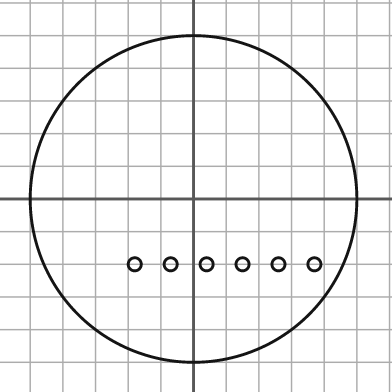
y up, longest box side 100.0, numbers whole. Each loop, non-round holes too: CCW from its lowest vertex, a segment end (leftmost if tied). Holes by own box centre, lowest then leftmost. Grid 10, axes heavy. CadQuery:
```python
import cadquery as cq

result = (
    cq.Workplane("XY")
    .moveTo(0.0, 0.0)
    .circle(50.0)
    .moveTo(-18.0, -20.0)
    .circle(2.0)
    .moveTo(-7.0, -20.0)
    .circle(2.0)
    .moveTo(4.0, -20.0)
    .circle(2.0)
    .moveTo(15.0, -20.0)
    .circle(2.0)
    .moveTo(26.0, -20.0)
    .circle(2.0)
    .moveTo(37.0, -20.0)
    .circle(2.0)
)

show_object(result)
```